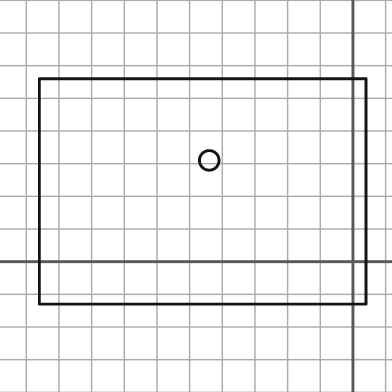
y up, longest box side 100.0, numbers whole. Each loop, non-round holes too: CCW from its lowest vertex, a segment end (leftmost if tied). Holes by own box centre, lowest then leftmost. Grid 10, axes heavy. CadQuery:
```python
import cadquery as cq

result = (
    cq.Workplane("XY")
    .moveTo(-96.0, -13.0)
    .lineTo(4.0, -13.0)
    .lineTo(4.0, 56.0)
    .lineTo(-96.0, 56.0)
    .close()
    .moveTo(-44.0, 31.0)
    .circle(3.0)
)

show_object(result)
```